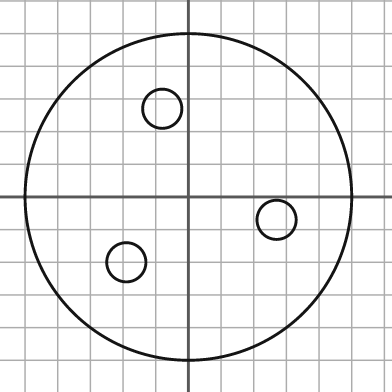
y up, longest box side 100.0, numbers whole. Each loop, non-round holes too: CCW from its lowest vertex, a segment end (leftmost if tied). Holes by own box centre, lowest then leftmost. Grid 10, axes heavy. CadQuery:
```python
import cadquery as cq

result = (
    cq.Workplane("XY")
    .moveTo(0.0, 0.0)
    .circle(50.0)
    .moveTo(-19.0, -20.0)
    .circle(6.0)
    .moveTo(27.0, -7.0)
    .circle(6.0)
    .moveTo(-8.0, 27.0)
    .circle(6.0)
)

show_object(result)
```